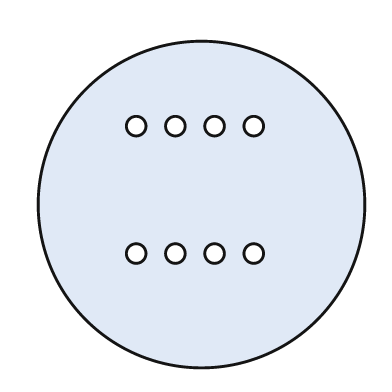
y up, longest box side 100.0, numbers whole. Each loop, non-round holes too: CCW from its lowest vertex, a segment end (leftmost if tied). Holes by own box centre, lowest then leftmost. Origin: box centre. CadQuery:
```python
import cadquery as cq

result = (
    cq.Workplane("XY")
    .moveTo(0.0, 0.0)
    .circle(50.0)
    .moveTo(-20.0, -15.0)
    .circle(3.0)
    .moveTo(-8.0, -15.0)
    .circle(3.0)
    .moveTo(4.0, -15.0)
    .circle(3.0)
    .moveTo(16.0, -15.0)
    .circle(3.0)
    .moveTo(-20.0, 24.0)
    .circle(3.0)
    .moveTo(-8.0, 24.0)
    .circle(3.0)
    .moveTo(4.0, 24.0)
    .circle(3.0)
    .moveTo(16.0, 24.0)
    .circle(3.0)
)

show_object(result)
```